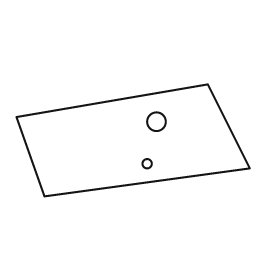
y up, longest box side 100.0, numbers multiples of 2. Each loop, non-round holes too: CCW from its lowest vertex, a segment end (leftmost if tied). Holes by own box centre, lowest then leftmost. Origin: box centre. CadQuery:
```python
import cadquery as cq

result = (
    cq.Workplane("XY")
    .moveTo(-38.0, -24.0)
    .lineTo(50.0, -12.0)
    .lineTo(32.0, 24.0)
    .lineTo(-50.0, 10.0)
    .close()
    .moveTo(6.0, -10.0)
    .circle(2.0)
    .moveTo(10.0, 8.0)
    .circle(4.0)
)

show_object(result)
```